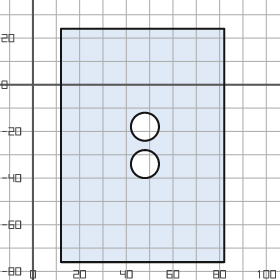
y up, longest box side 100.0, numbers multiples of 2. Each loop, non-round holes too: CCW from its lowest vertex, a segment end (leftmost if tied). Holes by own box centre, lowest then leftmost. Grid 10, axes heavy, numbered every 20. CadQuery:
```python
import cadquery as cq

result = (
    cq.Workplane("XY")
    .moveTo(12.0, -76.0)
    .lineTo(82.0, -76.0)
    .lineTo(82.0, 24.0)
    .lineTo(12.0, 24.0)
    .close()
    .moveTo(48.0, -34.0)
    .circle(6.0)
    .moveTo(48.0, -18.0)
    .circle(6.0)
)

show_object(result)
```